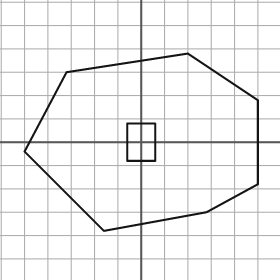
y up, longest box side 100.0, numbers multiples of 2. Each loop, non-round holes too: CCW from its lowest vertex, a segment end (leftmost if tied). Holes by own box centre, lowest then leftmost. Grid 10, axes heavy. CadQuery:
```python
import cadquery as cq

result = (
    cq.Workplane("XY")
    .moveTo(-16.0, -38.0)
    .lineTo(28.0, -30.0)
    .lineTo(50.0, -18.0)
    .lineTo(50.0, 18.0)
    .lineTo(20.0, 38.0)
    .lineTo(-32.0, 30.0)
    .lineTo(-50.0, -4.0)
    .close()
    .moveTo(-6.0, -8.0)
    .lineTo(6.0, -8.0)
    .lineTo(6.0, 8.0)
    .lineTo(-6.0, 8.0)
    .close()
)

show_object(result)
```